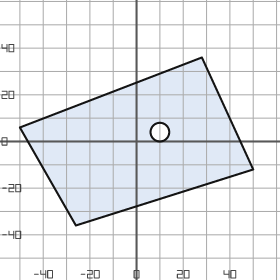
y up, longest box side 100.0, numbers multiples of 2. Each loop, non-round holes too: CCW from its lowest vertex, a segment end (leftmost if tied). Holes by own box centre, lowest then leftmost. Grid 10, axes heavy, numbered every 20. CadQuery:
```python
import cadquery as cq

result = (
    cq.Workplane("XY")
    .moveTo(-26.0, -36.0)
    .lineTo(50.0, -12.0)
    .lineTo(28.0, 36.0)
    .lineTo(-50.0, 6.0)
    .close()
    .moveTo(10.0, 4.0)
    .circle(4.0)
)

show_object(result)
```